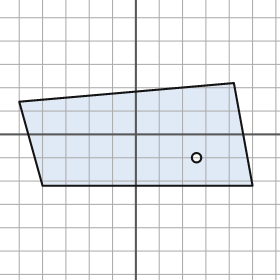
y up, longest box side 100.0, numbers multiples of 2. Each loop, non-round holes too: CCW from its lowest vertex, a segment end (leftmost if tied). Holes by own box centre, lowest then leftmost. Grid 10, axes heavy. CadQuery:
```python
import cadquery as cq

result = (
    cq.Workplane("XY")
    .moveTo(-40.0, -22.0)
    .lineTo(50.0, -22.0)
    .lineTo(42.0, 22.0)
    .lineTo(-50.0, 14.0)
    .close()
    .moveTo(26.0, -10.0)
    .circle(2.0)
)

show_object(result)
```